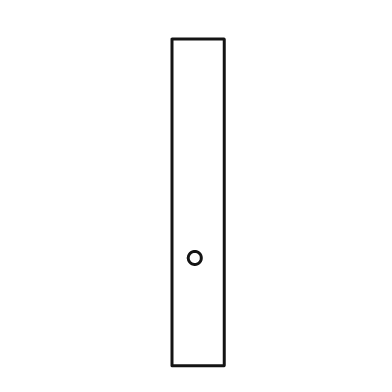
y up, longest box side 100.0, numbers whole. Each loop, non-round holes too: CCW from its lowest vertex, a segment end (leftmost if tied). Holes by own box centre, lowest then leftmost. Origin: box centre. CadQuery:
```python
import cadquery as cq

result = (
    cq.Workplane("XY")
    .moveTo(-8.0, -50.0)
    .lineTo(8.0, -50.0)
    .lineTo(8.0, 50.0)
    .lineTo(-8.0, 50.0)
    .close()
    .moveTo(-1.0, -17.0)
    .circle(2.0)
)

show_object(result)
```